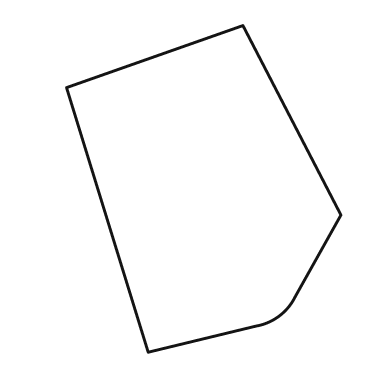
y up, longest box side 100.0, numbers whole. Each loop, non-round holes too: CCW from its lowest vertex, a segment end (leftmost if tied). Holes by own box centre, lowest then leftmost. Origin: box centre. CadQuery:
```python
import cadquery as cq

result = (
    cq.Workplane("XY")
    .moveTo(-17.0, -50.0)
    .lineTo(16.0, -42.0)
    .threePointArc((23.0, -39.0), (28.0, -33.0))
    .lineTo(42.0, -8.0)
    .lineTo(12.0, 50.0)
    .lineTo(-42.0, 31.0)
    .close()
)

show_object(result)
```